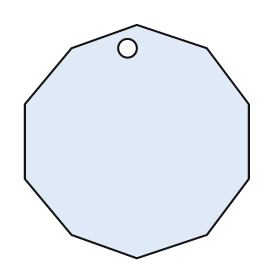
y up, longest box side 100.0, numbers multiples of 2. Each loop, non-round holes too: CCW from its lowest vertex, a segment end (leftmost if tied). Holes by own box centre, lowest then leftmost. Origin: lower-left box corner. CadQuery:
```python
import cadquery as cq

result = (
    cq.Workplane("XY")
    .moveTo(48.0, 0.0)
    .lineTo(78.0, 10.0)
    .lineTo(96.0, 34.0)
    .lineTo(96.0, 66.0)
    .lineTo(78.0, 90.0)
    .lineTo(48.0, 100.0)
    .lineTo(20.0, 90.0)
    .lineTo(0.0, 66.0)
    .lineTo(0.0, 34.0)
    .lineTo(20.0, 10.0)
    .close()
    .moveTo(44.0, 90.0)
    .circle(4.0)
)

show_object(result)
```